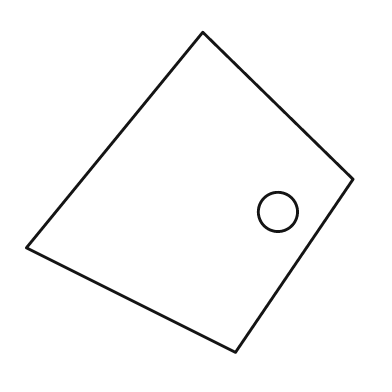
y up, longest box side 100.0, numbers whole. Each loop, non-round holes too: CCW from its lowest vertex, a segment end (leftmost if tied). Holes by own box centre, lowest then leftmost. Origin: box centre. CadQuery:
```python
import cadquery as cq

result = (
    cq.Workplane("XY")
    .moveTo(14.0, -49.0)
    .lineTo(50.0, 4.0)
    .lineTo(4.0, 49.0)
    .lineTo(-50.0, -17.0)
    .close()
    .moveTo(27.0, -6.0)
    .circle(6.0)
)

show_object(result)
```